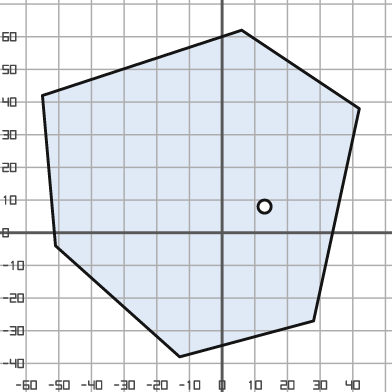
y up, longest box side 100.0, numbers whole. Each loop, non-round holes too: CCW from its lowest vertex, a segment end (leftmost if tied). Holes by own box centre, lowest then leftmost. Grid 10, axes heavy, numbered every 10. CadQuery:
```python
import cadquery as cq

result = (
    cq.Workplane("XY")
    .moveTo(-13.0, -38.0)
    .lineTo(28.0, -27.0)
    .lineTo(42.0, 38.0)
    .lineTo(6.0, 62.0)
    .lineTo(-55.0, 42.0)
    .lineTo(-51.0, -4.0)
    .close()
    .moveTo(13.0, 8.0)
    .circle(2.0)
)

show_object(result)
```